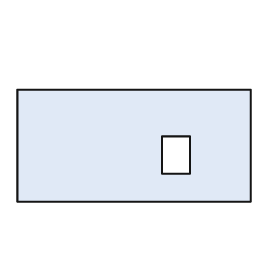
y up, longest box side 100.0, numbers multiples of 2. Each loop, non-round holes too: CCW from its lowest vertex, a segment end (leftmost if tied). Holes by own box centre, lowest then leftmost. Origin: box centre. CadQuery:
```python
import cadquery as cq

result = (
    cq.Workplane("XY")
    .moveTo(-50.0, -24.0)
    .lineTo(50.0, -24.0)
    .lineTo(50.0, 24.0)
    .lineTo(-50.0, 24.0)
    .close()
    .moveTo(12.0, -12.0)
    .lineTo(24.0, -12.0)
    .lineTo(24.0, 4.0)
    .lineTo(12.0, 4.0)
    .close()
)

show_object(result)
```